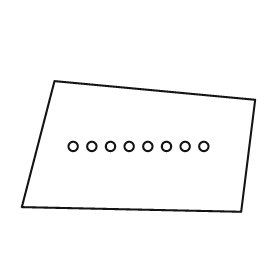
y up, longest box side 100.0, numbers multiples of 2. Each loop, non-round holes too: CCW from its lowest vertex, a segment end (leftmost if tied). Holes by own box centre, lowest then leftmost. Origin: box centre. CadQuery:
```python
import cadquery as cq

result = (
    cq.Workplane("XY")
    .moveTo(44.0, -28.0)
    .lineTo(50.0, 20.0)
    .lineTo(-36.0, 28.0)
    .lineTo(-50.0, -26.0)
    .close()
    .moveTo(-28.0, 0.0)
    .circle(2.0)
    .moveTo(-20.0, 0.0)
    .circle(2.0)
    .moveTo(-12.0, 0.0)
    .circle(2.0)
    .moveTo(-4.0, 0.0)
    .circle(2.0)
    .moveTo(4.0, 0.0)
    .circle(2.0)
    .moveTo(12.0, 0.0)
    .circle(2.0)
    .moveTo(20.0, 0.0)
    .circle(2.0)
    .moveTo(28.0, 0.0)
    .circle(2.0)
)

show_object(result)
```